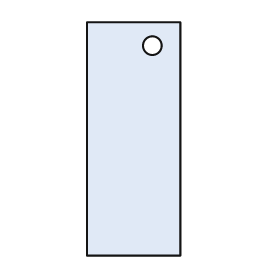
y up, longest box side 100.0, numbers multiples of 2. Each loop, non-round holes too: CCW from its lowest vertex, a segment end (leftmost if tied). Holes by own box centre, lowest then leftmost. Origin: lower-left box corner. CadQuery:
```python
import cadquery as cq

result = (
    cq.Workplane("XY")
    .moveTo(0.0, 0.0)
    .lineTo(40.0, 0.0)
    .lineTo(40.0, 100.0)
    .lineTo(0.0, 100.0)
    .close()
    .moveTo(28.0, 90.0)
    .circle(4.0)
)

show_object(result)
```